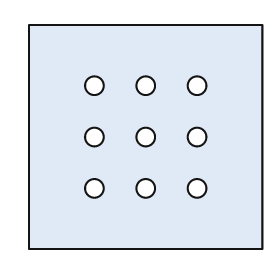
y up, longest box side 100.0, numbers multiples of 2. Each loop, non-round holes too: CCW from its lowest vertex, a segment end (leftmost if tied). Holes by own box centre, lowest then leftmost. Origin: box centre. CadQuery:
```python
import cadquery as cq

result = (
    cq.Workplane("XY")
    .moveTo(-50.0, -48.0)
    .lineTo(50.0, -48.0)
    .lineTo(50.0, 48.0)
    .lineTo(-50.0, 48.0)
    .close()
    .moveTo(-22.0, -22.0)
    .circle(4.0)
    .moveTo(0.0, -22.0)
    .circle(4.0)
    .moveTo(22.0, -22.0)
    .circle(4.0)
    .moveTo(-22.0, 0.0)
    .circle(4.0)
    .moveTo(0.0, 0.0)
    .circle(4.0)
    .moveTo(22.0, 0.0)
    .circle(4.0)
    .moveTo(-22.0, 22.0)
    .circle(4.0)
    .moveTo(0.0, 22.0)
    .circle(4.0)
    .moveTo(22.0, 22.0)
    .circle(4.0)
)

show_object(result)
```